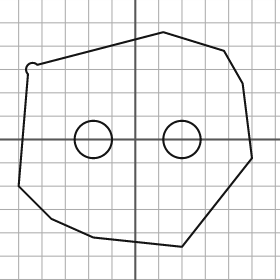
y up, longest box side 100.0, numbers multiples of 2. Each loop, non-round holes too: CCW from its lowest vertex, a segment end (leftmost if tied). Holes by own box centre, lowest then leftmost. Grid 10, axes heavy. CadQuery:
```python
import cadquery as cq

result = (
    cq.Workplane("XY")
    .moveTo(20.0, -46.0)
    .lineTo(50.0, -8.0)
    .lineTo(46.0, 24.0)
    .lineTo(38.0, 38.0)
    .lineTo(12.0, 46.0)
    .lineTo(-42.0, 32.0)
    .threePointArc((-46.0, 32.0), (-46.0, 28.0))
    .lineTo(-50.0, -20.0)
    .lineTo(-36.0, -34.0)
    .lineTo(-18.0, -42.0)
    .close()
    .moveTo(-18.0, 0.0)
    .circle(8.0)
    .moveTo(20.0, 0.0)
    .circle(8.0)
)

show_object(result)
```